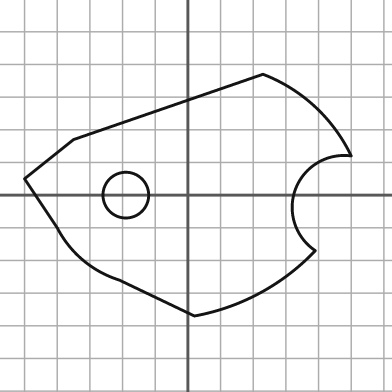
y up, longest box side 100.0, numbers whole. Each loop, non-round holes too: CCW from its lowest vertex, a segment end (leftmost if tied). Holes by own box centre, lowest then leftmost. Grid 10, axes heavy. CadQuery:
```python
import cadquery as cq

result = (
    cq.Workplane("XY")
    .moveTo(2.0, -37.0)
    .threePointArc((22.0, -30.0), (39.0, -17.0))
    .threePointArc((33.0, 2.0), (50.0, 12.0))
    .threePointArc((39.0, 27.0), (23.0, 37.0))
    .lineTo(-35.0, 17.0)
    .lineTo(-50.0, 5.0)
    .lineTo(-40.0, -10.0)
    .threePointArc((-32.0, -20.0), (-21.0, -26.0))
    .close()
    .moveTo(-19.0, 0.0)
    .circle(7.0)
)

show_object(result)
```